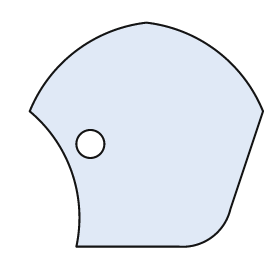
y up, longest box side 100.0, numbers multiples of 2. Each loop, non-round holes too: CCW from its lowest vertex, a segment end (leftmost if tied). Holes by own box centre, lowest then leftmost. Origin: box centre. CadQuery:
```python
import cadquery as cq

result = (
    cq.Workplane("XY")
    .moveTo(-30.0, -48.0)
    .lineTo(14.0, -48.0)
    .threePointArc((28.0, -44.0), (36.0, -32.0))
    .lineTo(50.0, 10.0)
    .threePointArc((30.0, 36.0), (0.0, 48.0))
    .threePointArc((-30.0, 36.0), (-50.0, 10.0))
    .threePointArc((-32.0, -16.0), (-30.0, -48.0))
    .close()
    .moveTo(-24.0, -4.0)
    .circle(6.0)
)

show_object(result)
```